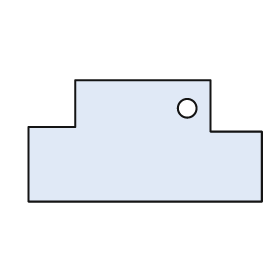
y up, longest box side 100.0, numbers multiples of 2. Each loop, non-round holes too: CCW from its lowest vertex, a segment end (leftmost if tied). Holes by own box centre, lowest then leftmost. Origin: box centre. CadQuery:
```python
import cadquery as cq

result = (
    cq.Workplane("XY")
    .moveTo(-50.0, -26.0)
    .lineTo(50.0, -26.0)
    .lineTo(50.0, 4.0)
    .lineTo(28.0, 4.0)
    .lineTo(28.0, 26.0)
    .lineTo(-30.0, 26.0)
    .lineTo(-30.0, 6.0)
    .lineTo(-50.0, 6.0)
    .close()
    .moveTo(18.0, 14.0)
    .circle(4.0)
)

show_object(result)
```